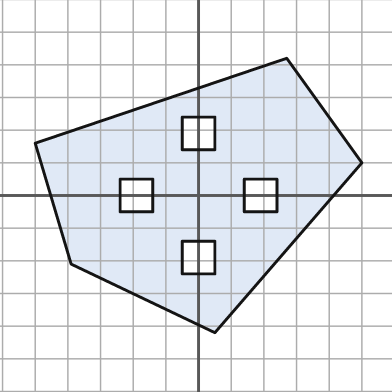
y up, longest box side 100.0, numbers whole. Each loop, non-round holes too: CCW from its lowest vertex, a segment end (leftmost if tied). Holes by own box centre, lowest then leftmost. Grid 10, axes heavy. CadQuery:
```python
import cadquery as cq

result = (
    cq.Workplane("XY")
    .moveTo(5.0, -42.0)
    .lineTo(50.0, 10.0)
    .lineTo(27.0, 42.0)
    .lineTo(-50.0, 16.0)
    .lineTo(-39.0, -21.0)
    .close()
    .moveTo(-5.0, -24.0)
    .lineTo(5.0, -24.0)
    .lineTo(5.0, -14.0)
    .lineTo(-5.0, -14.0)
    .close()
    .moveTo(-24.0, -5.0)
    .lineTo(-14.0, -5.0)
    .lineTo(-14.0, 5.0)
    .lineTo(-24.0, 5.0)
    .close()
    .moveTo(14.0, -5.0)
    .lineTo(24.0, -5.0)
    .lineTo(24.0, 5.0)
    .lineTo(14.0, 5.0)
    .close()
    .moveTo(-5.0, 14.0)
    .lineTo(5.0, 14.0)
    .lineTo(5.0, 24.0)
    .lineTo(-5.0, 24.0)
    .close()
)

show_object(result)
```